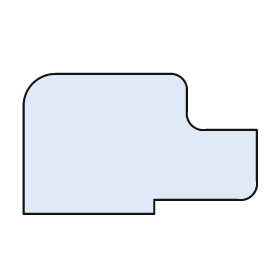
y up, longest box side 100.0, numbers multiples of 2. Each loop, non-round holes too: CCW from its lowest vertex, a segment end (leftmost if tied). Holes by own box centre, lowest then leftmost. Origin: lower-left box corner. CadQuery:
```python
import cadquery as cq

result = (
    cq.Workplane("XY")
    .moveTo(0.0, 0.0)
    .lineTo(56.0, 0.0)
    .lineTo(56.0, 6.0)
    .lineTo(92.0, 6.0)
    .threePointArc((98.0, 8.0), (100.0, 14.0))
    .lineTo(100.0, 36.0)
    .lineTo(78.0, 36.0)
    .threePointArc((72.0, 38.0), (70.0, 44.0))
    .lineTo(70.0, 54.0)
    .threePointArc((68.0, 58.0), (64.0, 60.0))
    .lineTo(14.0, 60.0)
    .threePointArc((4.0, 56.0), (0.0, 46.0))
    .close()
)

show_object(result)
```